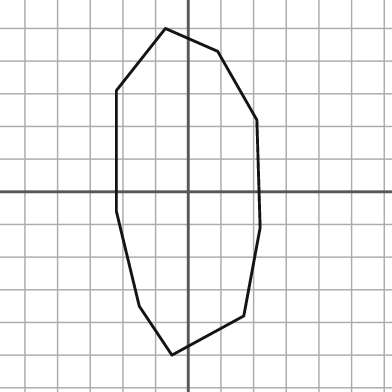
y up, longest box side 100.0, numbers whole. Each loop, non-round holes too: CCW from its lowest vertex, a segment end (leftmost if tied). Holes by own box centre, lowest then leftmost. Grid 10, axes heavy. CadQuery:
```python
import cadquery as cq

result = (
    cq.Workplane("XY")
    .moveTo(-5.0, -50.0)
    .lineTo(17.0, -38.0)
    .lineTo(22.0, -11.0)
    .lineTo(21.0, 22.0)
    .lineTo(9.0, 43.0)
    .lineTo(-7.0, 50.0)
    .lineTo(-22.0, 31.0)
    .lineTo(-22.0, -6.0)
    .lineTo(-15.0, -35.0)
    .close()
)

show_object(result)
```